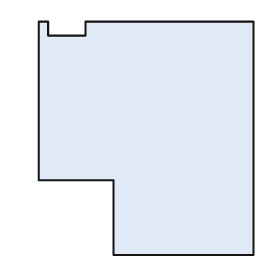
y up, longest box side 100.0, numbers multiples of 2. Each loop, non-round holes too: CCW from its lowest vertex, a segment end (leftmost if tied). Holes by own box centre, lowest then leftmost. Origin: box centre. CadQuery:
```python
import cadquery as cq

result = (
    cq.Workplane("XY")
    .moveTo(-14.0, -50.0)
    .lineTo(46.0, -50.0)
    .lineTo(46.0, 50.0)
    .lineTo(-26.0, 50.0)
    .lineTo(-26.0, 44.0)
    .lineTo(-42.0, 44.0)
    .lineTo(-42.0, 50.0)
    .lineTo(-46.0, 50.0)
    .lineTo(-46.0, -18.0)
    .lineTo(-14.0, -18.0)
    .close()
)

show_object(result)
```